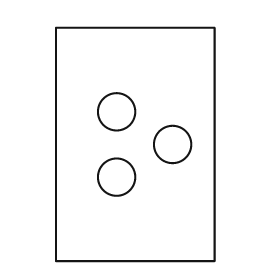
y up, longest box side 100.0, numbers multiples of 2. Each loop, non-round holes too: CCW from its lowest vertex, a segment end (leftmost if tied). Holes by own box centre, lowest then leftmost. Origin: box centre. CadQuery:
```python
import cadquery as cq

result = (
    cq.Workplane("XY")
    .moveTo(-34.0, -50.0)
    .lineTo(34.0, -50.0)
    .lineTo(34.0, 50.0)
    .lineTo(-34.0, 50.0)
    .close()
    .moveTo(-8.0, -14.0)
    .circle(8.0)
    .moveTo(16.0, 0.0)
    .circle(8.0)
    .moveTo(-8.0, 14.0)
    .circle(8.0)
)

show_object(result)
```